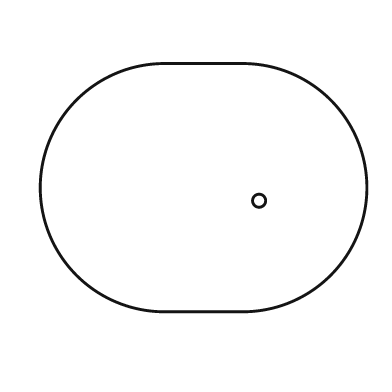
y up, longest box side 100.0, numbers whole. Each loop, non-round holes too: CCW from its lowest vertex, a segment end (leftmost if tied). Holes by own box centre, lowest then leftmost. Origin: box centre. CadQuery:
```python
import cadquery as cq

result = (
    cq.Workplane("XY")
    .moveTo(-12.0, -38.0)
    .lineTo(12.0, -38.0)
    .threePointArc((50.0, 0.0), (12.0, 38.0))
    .lineTo(-12.0, 38.0)
    .threePointArc((-50.0, 0.0), (-12.0, -38.0))
    .close()
    .moveTo(17.0, -4.0)
    .circle(2.0)
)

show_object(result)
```